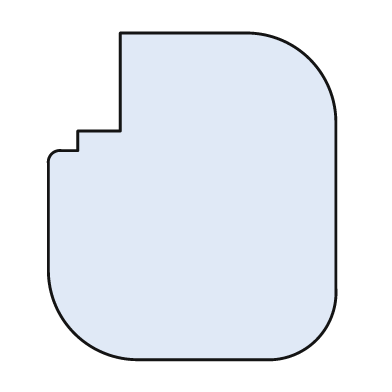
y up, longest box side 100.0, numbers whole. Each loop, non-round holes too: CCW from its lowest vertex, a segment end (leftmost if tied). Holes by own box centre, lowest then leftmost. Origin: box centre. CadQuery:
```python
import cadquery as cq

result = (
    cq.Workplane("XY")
    .moveTo(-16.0, -50.0)
    .lineTo(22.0, -50.0)
    .threePointArc((38.0, -44.0), (44.0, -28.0))
    .lineTo(44.0, 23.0)
    .threePointArc((36.0, 42.0), (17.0, 50.0))
    .lineTo(-22.0, 50.0)
    .lineTo(-22.0, 20.0)
    .lineTo(-35.0, 20.0)
    .lineTo(-35.0, 14.0)
    .lineTo(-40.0, 14.0)
    .threePointArc((-43.0, 13.0), (-44.0, 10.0))
    .lineTo(-44.0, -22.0)
    .threePointArc((-36.0, -42.0), (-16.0, -50.0))
    .close()
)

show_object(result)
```